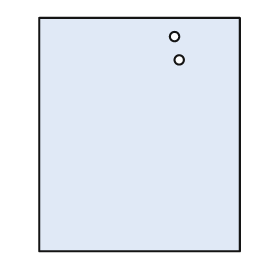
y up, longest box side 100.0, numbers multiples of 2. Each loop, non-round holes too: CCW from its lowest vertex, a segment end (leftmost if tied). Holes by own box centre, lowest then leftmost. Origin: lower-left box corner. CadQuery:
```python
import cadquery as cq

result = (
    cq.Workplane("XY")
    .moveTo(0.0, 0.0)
    .lineTo(86.0, 0.0)
    .lineTo(86.0, 100.0)
    .lineTo(0.0, 100.0)
    .close()
    .moveTo(60.0, 82.0)
    .circle(2.0)
    .moveTo(58.0, 92.0)
    .circle(2.0)
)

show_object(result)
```